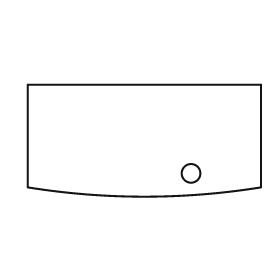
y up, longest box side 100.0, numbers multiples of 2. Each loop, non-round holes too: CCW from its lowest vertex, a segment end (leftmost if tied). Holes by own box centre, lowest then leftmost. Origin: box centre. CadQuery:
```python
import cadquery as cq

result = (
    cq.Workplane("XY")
    .moveTo(-50.0, -20.0)
    .threePointArc((0.0, -24.0), (50.0, -20.0))
    .lineTo(50.0, 24.0)
    .lineTo(-50.0, 24.0)
    .close()
    .moveTo(20.0, -14.0)
    .circle(4.0)
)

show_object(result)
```